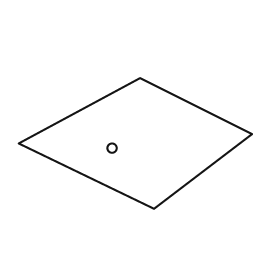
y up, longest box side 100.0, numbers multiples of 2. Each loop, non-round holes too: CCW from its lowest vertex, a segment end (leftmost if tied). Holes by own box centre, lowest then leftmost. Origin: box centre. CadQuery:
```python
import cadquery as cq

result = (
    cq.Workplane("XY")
    .moveTo(8.0, -28.0)
    .lineTo(50.0, 4.0)
    .lineTo(2.0, 28.0)
    .lineTo(-50.0, 0.0)
    .close()
    .moveTo(-10.0, -2.0)
    .circle(2.0)
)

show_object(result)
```